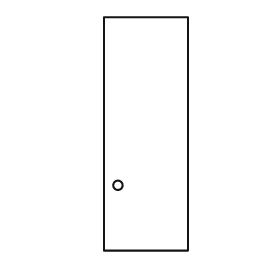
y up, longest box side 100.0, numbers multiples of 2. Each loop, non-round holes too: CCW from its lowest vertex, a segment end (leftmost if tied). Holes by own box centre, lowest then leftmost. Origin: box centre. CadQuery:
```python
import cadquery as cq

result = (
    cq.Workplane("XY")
    .moveTo(-18.0, -50.0)
    .lineTo(18.0, -50.0)
    .lineTo(18.0, 50.0)
    .lineTo(-18.0, 50.0)
    .close()
    .moveTo(-12.0, -22.0)
    .circle(2.0)
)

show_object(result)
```